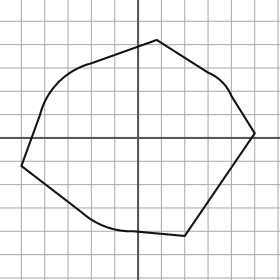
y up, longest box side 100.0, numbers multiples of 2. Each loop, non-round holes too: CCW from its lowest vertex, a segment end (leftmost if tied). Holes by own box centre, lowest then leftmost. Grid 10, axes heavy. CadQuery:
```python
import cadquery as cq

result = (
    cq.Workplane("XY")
    .moveTo(20.0, -42.0)
    .lineTo(50.0, 2.0)
    .lineTo(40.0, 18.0)
    .threePointArc((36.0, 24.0), (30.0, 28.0))
    .lineTo(8.0, 42.0)
    .lineTo(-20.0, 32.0)
    .threePointArc((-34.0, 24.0), (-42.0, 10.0))
    .lineTo(-50.0, -12.0)
    .lineTo(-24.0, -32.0)
    .threePointArc((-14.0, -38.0), (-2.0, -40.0))
    .close()
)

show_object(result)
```